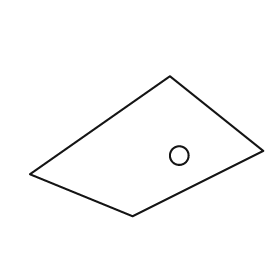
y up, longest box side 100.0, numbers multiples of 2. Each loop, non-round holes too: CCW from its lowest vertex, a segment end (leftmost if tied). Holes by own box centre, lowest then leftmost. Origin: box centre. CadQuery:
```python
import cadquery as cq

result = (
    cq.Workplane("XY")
    .moveTo(-6.0, -30.0)
    .lineTo(50.0, -2.0)
    .lineTo(10.0, 30.0)
    .lineTo(-50.0, -12.0)
    .close()
    .moveTo(14.0, -4.0)
    .circle(4.0)
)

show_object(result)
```